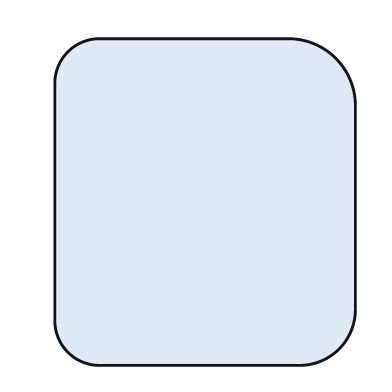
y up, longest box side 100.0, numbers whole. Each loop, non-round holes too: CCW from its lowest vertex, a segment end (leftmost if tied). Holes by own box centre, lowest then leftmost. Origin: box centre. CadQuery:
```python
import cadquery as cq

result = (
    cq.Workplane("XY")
    .moveTo(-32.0, -50.0)
    .lineTo(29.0, -50.0)
    .threePointArc((41.0, -45.0), (46.0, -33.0))
    .lineTo(46.0, 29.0)
    .threePointArc((40.0, 44.0), (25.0, 50.0))
    .lineTo(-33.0, 50.0)
    .threePointArc((-42.0, 46.0), (-46.0, 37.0))
    .lineTo(-46.0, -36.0)
    .threePointArc((-42.0, -46.0), (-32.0, -50.0))
    .close()
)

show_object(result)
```